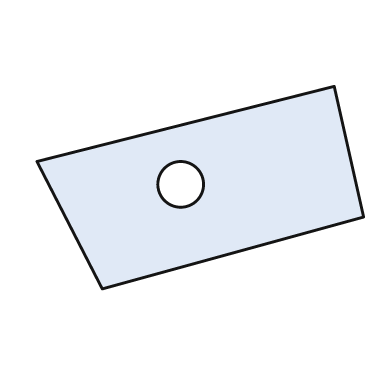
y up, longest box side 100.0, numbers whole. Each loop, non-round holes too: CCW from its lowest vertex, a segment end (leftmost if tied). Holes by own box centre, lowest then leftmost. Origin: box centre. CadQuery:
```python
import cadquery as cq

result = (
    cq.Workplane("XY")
    .moveTo(-30.0, -31.0)
    .lineTo(50.0, -9.0)
    .lineTo(41.0, 31.0)
    .lineTo(-50.0, 8.0)
    .close()
    .moveTo(-6.0, 1.0)
    .circle(7.0)
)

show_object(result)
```